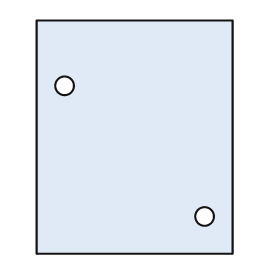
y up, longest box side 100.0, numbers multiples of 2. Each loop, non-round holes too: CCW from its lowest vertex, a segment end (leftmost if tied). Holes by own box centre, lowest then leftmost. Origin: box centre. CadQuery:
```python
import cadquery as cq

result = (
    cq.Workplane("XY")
    .moveTo(-42.0, -50.0)
    .lineTo(42.0, -50.0)
    .lineTo(42.0, 50.0)
    .lineTo(-42.0, 50.0)
    .close()
    .moveTo(30.0, -34.0)
    .circle(4.0)
    .moveTo(-30.0, 22.0)
    .circle(4.0)
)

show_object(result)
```